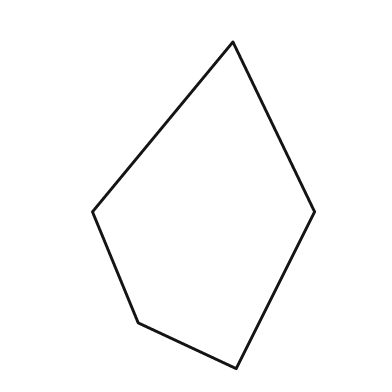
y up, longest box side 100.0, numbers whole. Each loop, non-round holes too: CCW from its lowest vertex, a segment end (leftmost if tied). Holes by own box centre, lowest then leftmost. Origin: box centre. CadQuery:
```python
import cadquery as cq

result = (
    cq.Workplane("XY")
    .moveTo(10.0, -50.0)
    .lineTo(34.0, -2.0)
    .lineTo(9.0, 50.0)
    .lineTo(-34.0, -2.0)
    .lineTo(-20.0, -36.0)
    .close()
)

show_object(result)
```